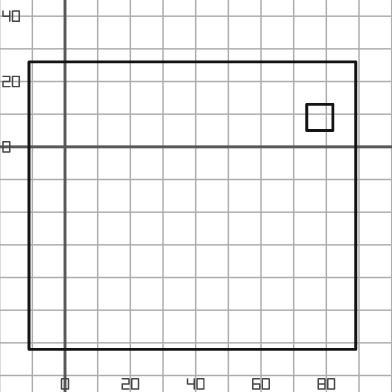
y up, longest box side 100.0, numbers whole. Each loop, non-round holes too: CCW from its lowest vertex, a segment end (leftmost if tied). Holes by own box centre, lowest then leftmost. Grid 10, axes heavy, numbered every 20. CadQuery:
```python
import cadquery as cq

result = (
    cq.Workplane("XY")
    .moveTo(-11.0, -62.0)
    .lineTo(89.0, -62.0)
    .lineTo(89.0, 26.0)
    .lineTo(-11.0, 26.0)
    .close()
    .moveTo(74.0, 5.0)
    .lineTo(82.0, 5.0)
    .lineTo(82.0, 13.0)
    .lineTo(74.0, 13.0)
    .close()
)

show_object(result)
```